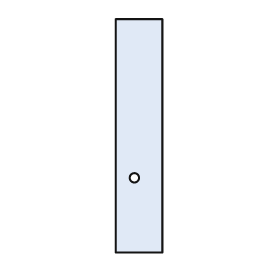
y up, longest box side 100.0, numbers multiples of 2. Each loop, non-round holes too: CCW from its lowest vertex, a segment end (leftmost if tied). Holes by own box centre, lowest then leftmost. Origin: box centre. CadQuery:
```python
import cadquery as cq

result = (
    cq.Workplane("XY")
    .moveTo(-10.0, -50.0)
    .lineTo(10.0, -50.0)
    .lineTo(10.0, 50.0)
    .lineTo(-10.0, 50.0)
    .close()
    .moveTo(-2.0, -18.0)
    .circle(2.0)
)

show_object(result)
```